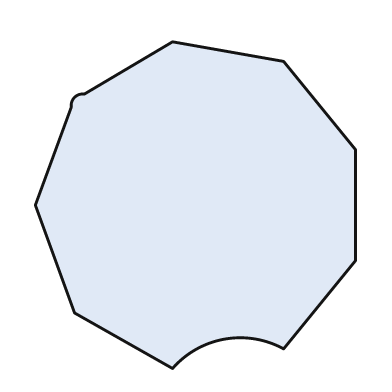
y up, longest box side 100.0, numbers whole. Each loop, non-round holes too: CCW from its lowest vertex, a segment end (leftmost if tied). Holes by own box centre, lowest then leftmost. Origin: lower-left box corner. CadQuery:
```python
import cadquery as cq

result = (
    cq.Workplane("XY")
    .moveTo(42.0, 0.0)
    .threePointArc((58.0, 9.0), (76.0, 6.0))
    .lineTo(98.0, 33.0)
    .lineTo(98.0, 67.0)
    .lineTo(76.0, 94.0)
    .lineTo(42.0, 100.0)
    .lineTo(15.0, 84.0)
    .threePointArc((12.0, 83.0), (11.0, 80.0))
    .lineTo(0.0, 50.0)
    .lineTo(12.0, 17.0)
    .close()
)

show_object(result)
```